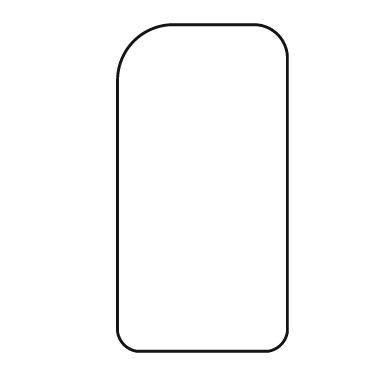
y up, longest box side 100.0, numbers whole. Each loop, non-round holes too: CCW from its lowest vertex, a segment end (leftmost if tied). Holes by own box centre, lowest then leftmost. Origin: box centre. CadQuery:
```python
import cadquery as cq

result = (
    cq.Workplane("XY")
    .moveTo(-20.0, -50.0)
    .lineTo(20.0, -50.0)
    .threePointArc((24.0, -48.0), (26.0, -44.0))
    .lineTo(26.0, 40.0)
    .threePointArc((23.0, 47.0), (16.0, 50.0))
    .lineTo(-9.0, 50.0)
    .threePointArc((-21.0, 45.0), (-26.0, 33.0))
    .lineTo(-26.0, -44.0)
    .threePointArc((-24.0, -48.0), (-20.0, -50.0))
    .close()
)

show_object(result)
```